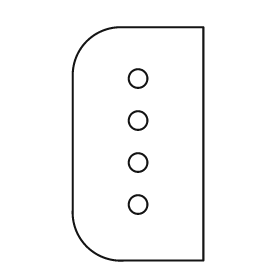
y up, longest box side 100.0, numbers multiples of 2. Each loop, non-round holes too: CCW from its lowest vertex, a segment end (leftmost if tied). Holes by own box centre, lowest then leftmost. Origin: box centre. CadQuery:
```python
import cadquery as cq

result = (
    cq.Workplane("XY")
    .moveTo(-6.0, -50.0)
    .lineTo(28.0, -50.0)
    .lineTo(28.0, 50.0)
    .lineTo(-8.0, 50.0)
    .threePointArc((-22.0, 44.0), (-28.0, 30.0))
    .lineTo(-28.0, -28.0)
    .threePointArc((-22.0, -44.0), (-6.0, -50.0))
    .close()
    .moveTo(0.0, -26.0)
    .circle(4.0)
    .moveTo(0.0, -8.0)
    .circle(4.0)
    .moveTo(0.0, 10.0)
    .circle(4.0)
    .moveTo(0.0, 28.0)
    .circle(4.0)
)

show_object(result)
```